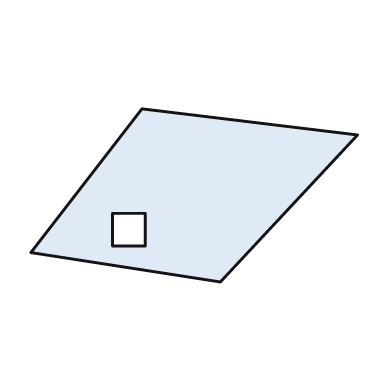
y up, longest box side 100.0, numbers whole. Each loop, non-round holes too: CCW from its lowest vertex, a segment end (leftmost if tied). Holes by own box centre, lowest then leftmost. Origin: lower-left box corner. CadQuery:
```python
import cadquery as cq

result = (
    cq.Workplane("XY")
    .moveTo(58.0, 0.0)
    .lineTo(100.0, 45.0)
    .lineTo(34.0, 53.0)
    .lineTo(0.0, 9.0)
    .close()
    .moveTo(25.0, 11.0)
    .lineTo(35.0, 11.0)
    .lineTo(35.0, 21.0)
    .lineTo(25.0, 21.0)
    .close()
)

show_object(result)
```